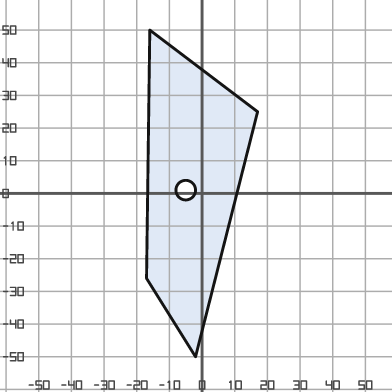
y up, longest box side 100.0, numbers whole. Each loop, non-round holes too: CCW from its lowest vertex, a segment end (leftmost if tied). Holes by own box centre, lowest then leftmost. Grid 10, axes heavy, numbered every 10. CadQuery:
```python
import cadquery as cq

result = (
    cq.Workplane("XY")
    .moveTo(-2.0, -50.0)
    .lineTo(17.0, 25.0)
    .lineTo(-16.0, 50.0)
    .lineTo(-17.0, -26.0)
    .close()
    .moveTo(-5.0, 1.0)
    .circle(3.0)
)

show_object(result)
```